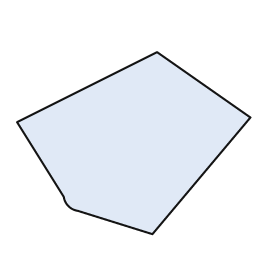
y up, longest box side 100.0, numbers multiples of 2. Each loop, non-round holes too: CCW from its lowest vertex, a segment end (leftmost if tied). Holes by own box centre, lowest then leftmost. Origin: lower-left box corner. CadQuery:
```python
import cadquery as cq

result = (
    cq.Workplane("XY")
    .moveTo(58.0, 0.0)
    .lineTo(100.0, 50.0)
    .lineTo(60.0, 78.0)
    .lineTo(0.0, 48.0)
    .lineTo(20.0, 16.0)
    .threePointArc((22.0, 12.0), (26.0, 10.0))
    .close()
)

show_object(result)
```